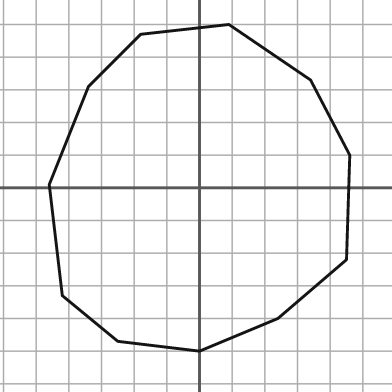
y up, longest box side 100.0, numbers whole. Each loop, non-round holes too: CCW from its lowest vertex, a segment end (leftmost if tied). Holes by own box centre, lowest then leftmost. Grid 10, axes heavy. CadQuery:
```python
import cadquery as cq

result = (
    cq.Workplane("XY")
    .moveTo(0.0, -50.0)
    .lineTo(24.0, -40.0)
    .lineTo(45.0, -22.0)
    .lineTo(46.0, 10.0)
    .lineTo(34.0, 33.0)
    .lineTo(9.0, 50.0)
    .lineTo(-18.0, 47.0)
    .lineTo(-34.0, 31.0)
    .lineTo(-46.0, 1.0)
    .lineTo(-42.0, -33.0)
    .lineTo(-25.0, -47.0)
    .close()
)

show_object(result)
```